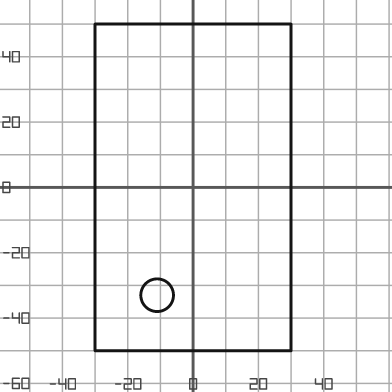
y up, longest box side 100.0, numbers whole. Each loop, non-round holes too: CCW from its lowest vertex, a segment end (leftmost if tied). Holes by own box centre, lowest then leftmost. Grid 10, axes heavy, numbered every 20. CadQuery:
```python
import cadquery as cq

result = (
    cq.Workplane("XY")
    .moveTo(-30.0, -50.0)
    .lineTo(30.0, -50.0)
    .lineTo(30.0, 50.0)
    .lineTo(-30.0, 50.0)
    .close()
    .moveTo(-11.0, -33.0)
    .circle(5.0)
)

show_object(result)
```